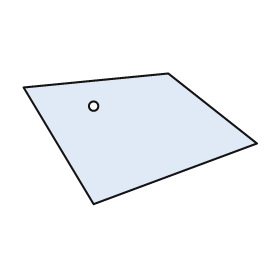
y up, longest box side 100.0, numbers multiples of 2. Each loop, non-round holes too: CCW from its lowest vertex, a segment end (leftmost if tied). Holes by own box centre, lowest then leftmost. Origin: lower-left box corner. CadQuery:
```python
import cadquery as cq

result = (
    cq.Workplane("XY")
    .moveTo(30.0, 0.0)
    .lineTo(100.0, 26.0)
    .lineTo(62.0, 56.0)
    .lineTo(0.0, 50.0)
    .close()
    .moveTo(30.0, 42.0)
    .circle(2.0)
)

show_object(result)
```